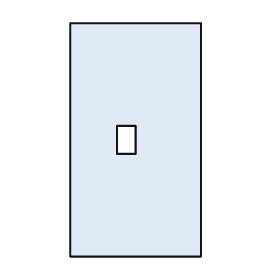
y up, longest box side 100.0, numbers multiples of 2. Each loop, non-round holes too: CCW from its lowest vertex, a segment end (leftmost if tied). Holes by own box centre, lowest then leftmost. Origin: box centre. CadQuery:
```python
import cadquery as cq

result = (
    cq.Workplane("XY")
    .moveTo(-28.0, -50.0)
    .lineTo(28.0, -50.0)
    .lineTo(28.0, 50.0)
    .lineTo(-28.0, 50.0)
    .close()
    .moveTo(-8.0, -6.0)
    .lineTo(0.0, -6.0)
    .lineTo(0.0, 6.0)
    .lineTo(-8.0, 6.0)
    .close()
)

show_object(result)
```